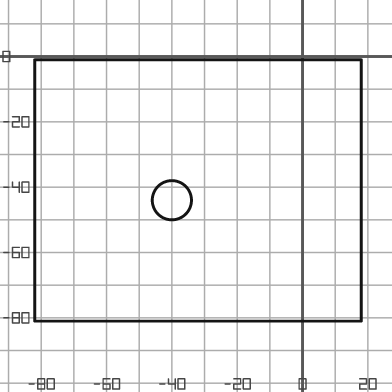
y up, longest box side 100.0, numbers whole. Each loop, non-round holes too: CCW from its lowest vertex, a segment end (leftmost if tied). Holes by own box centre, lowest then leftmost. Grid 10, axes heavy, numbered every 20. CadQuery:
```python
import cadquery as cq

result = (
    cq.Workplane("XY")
    .moveTo(-82.0, -81.0)
    .lineTo(18.0, -81.0)
    .lineTo(18.0, -1.0)
    .lineTo(-82.0, -1.0)
    .close()
    .moveTo(-40.0, -44.0)
    .circle(6.0)
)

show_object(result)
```